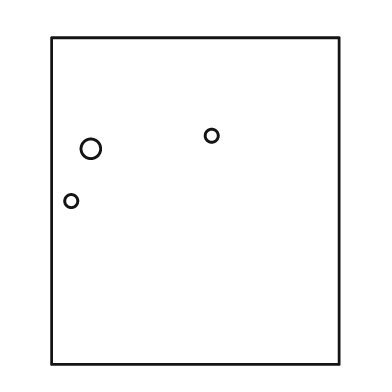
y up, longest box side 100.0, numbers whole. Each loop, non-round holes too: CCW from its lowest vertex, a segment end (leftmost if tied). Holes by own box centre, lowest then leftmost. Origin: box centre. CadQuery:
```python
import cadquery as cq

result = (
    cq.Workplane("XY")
    .moveTo(-44.0, -50.0)
    .lineTo(44.0, -50.0)
    .lineTo(44.0, 50.0)
    .lineTo(-44.0, 50.0)
    .close()
    .moveTo(-38.0, 0.0)
    .circle(2.0)
    .moveTo(-32.0, 16.0)
    .circle(3.0)
    .moveTo(5.0, 20.0)
    .circle(2.0)
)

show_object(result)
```